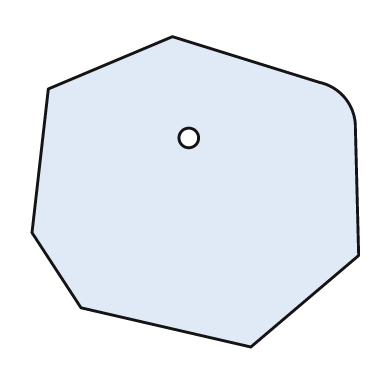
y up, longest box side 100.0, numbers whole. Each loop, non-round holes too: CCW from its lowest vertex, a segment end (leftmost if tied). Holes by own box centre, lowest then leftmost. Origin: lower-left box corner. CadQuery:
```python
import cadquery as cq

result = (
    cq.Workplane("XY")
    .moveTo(67.0, 0.0)
    .lineTo(100.0, 28.0)
    .lineTo(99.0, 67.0)
    .threePointArc((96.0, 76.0), (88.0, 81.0))
    .lineTo(43.0, 95.0)
    .lineTo(5.0, 79.0)
    .lineTo(0.0, 35.0)
    .lineTo(15.0, 12.0)
    .close()
    .moveTo(48.0, 64.0)
    .circle(3.0)
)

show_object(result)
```